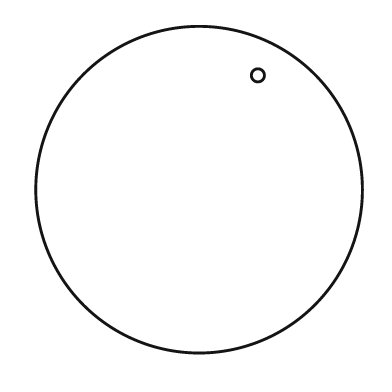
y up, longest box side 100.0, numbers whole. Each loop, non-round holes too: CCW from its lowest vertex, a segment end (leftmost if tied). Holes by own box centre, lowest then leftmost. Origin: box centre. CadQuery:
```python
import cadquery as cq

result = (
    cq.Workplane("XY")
    .moveTo(0.0, 0.0)
    .circle(50.0)
    .moveTo(18.0, 35.0)
    .circle(2.0)
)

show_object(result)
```